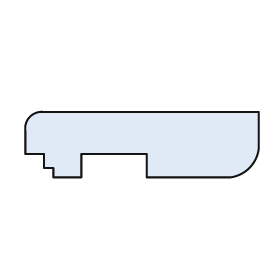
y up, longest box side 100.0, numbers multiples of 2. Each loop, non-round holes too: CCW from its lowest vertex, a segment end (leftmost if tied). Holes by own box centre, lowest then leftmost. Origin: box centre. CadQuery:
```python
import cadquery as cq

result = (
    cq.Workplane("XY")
    .moveTo(-38.0, -14.0)
    .lineTo(-26.0, -14.0)
    .lineTo(-26.0, -4.0)
    .lineTo(2.0, -4.0)
    .lineTo(2.0, -14.0)
    .lineTo(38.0, -14.0)
    .threePointArc((46.0, -10.0), (50.0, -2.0))
    .lineTo(50.0, 14.0)
    .lineTo(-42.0, 14.0)
    .threePointArc((-48.0, 12.0), (-50.0, 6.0))
    .lineTo(-50.0, -4.0)
    .lineTo(-42.0, -4.0)
    .lineTo(-42.0, -10.0)
    .lineTo(-38.0, -10.0)
    .close()
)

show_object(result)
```